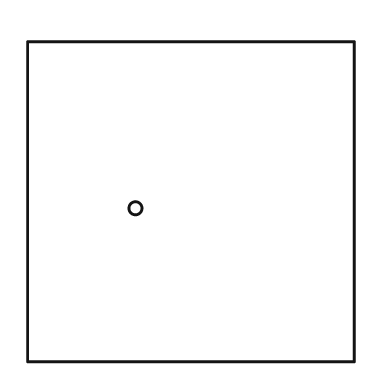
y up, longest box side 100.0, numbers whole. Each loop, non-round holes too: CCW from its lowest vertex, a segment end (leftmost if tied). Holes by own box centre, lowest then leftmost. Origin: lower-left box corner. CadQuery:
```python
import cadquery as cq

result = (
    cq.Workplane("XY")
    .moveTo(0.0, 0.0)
    .lineTo(100.0, 0.0)
    .lineTo(100.0, 98.0)
    .lineTo(0.0, 98.0)
    .close()
    .moveTo(33.0, 47.0)
    .circle(2.0)
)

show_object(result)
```